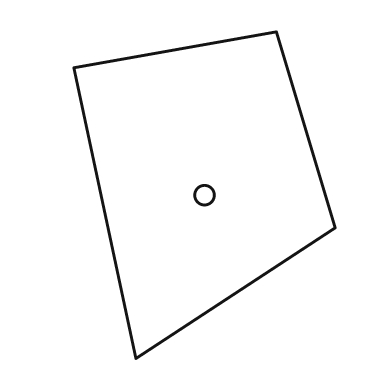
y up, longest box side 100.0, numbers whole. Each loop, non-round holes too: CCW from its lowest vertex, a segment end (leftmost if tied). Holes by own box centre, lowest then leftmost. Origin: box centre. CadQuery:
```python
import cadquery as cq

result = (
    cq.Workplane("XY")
    .moveTo(-21.0, -50.0)
    .lineTo(40.0, -10.0)
    .lineTo(22.0, 50.0)
    .lineTo(-40.0, 39.0)
    .close()
    .moveTo(0.0, 0.0)
    .circle(3.0)
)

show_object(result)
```